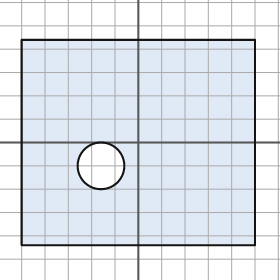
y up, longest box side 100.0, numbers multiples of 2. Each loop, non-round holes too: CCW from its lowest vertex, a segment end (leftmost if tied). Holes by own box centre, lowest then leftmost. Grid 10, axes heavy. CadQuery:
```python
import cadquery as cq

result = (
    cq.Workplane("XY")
    .moveTo(-50.0, -44.0)
    .lineTo(50.0, -44.0)
    .lineTo(50.0, 44.0)
    .lineTo(-50.0, 44.0)
    .close()
    .moveTo(-16.0, -10.0)
    .circle(10.0)
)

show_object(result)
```